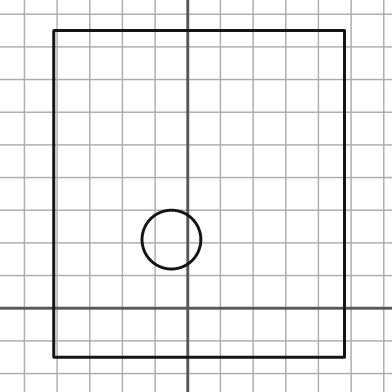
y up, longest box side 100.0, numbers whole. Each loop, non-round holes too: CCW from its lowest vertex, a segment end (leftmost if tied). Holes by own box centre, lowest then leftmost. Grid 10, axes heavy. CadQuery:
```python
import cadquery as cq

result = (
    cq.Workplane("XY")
    .moveTo(-41.0, -15.0)
    .lineTo(48.0, -15.0)
    .lineTo(48.0, 85.0)
    .lineTo(-41.0, 85.0)
    .close()
    .moveTo(-5.0, 21.0)
    .circle(9.0)
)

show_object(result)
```